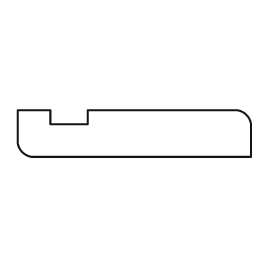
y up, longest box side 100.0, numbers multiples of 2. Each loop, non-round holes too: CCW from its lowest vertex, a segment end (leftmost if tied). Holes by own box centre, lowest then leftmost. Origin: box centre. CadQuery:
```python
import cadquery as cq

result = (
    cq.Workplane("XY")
    .moveTo(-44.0, -10.0)
    .lineTo(50.0, -10.0)
    .lineTo(50.0, 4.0)
    .threePointArc((48.0, 8.0), (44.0, 10.0))
    .lineTo(-20.0, 10.0)
    .lineTo(-20.0, 4.0)
    .lineTo(-36.0, 4.0)
    .lineTo(-36.0, 10.0)
    .lineTo(-50.0, 10.0)
    .lineTo(-50.0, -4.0)
    .threePointArc((-48.0, -8.0), (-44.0, -10.0))
    .close()
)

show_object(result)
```